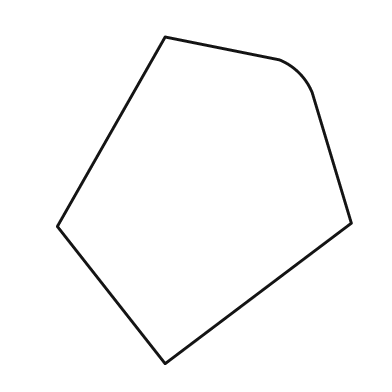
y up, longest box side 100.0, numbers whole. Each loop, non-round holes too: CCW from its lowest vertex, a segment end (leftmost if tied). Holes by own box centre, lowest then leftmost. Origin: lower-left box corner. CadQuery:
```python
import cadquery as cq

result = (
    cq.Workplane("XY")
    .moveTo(33.0, 0.0)
    .lineTo(90.0, 43.0)
    .lineTo(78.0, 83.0)
    .threePointArc((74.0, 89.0), (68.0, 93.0))
    .lineTo(33.0, 100.0)
    .lineTo(0.0, 42.0)
    .close()
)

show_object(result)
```